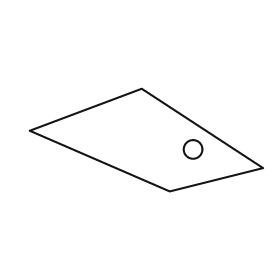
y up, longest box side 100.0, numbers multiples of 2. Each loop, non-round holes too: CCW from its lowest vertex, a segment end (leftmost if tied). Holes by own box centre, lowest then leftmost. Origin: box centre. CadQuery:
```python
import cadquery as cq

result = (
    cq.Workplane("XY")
    .moveTo(10.0, -22.0)
    .lineTo(50.0, -12.0)
    .lineTo(-2.0, 22.0)
    .lineTo(-50.0, 4.0)
    .close()
    .moveTo(20.0, -4.0)
    .circle(4.0)
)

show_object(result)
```